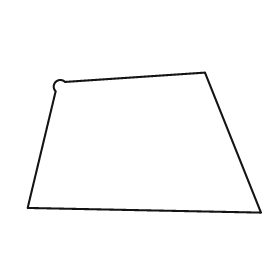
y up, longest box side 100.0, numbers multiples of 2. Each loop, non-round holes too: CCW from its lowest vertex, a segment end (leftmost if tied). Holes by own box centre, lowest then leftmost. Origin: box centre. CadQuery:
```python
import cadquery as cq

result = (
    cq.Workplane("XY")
    .moveTo(50.0, -30.0)
    .lineTo(26.0, 30.0)
    .lineTo(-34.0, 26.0)
    .threePointArc((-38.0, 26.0), (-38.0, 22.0))
    .lineTo(-50.0, -28.0)
    .close()
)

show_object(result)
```